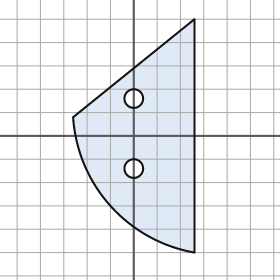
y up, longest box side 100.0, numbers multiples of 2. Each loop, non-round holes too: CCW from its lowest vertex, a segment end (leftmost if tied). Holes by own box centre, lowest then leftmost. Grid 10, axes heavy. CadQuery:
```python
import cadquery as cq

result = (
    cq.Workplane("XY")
    .moveTo(26.0, -50.0)
    .lineTo(26.0, 50.0)
    .lineTo(-26.0, 8.0)
    .threePointArc((-10.0, -30.0), (26.0, -50.0))
    .close()
    .moveTo(0.0, -14.0)
    .circle(4.0)
    .moveTo(0.0, 16.0)
    .circle(4.0)
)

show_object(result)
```